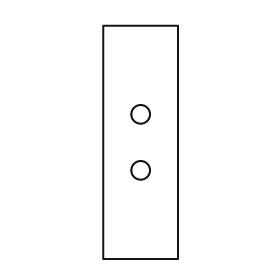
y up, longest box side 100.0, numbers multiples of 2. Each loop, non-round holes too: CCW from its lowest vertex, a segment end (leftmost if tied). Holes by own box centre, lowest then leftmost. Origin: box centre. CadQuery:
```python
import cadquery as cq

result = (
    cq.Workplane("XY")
    .moveTo(-16.0, -50.0)
    .lineTo(16.0, -50.0)
    .lineTo(16.0, 50.0)
    .lineTo(-16.0, 50.0)
    .close()
    .moveTo(0.0, -12.0)
    .circle(4.0)
    .moveTo(0.0, 12.0)
    .circle(4.0)
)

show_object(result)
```